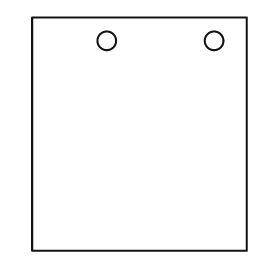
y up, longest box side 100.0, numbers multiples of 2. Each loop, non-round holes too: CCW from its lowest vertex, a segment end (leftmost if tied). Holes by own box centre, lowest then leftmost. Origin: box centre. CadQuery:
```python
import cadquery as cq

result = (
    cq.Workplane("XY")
    .moveTo(-46.0, -50.0)
    .lineTo(46.0, -50.0)
    .lineTo(46.0, 50.0)
    .lineTo(-46.0, 50.0)
    .close()
    .moveTo(-14.0, 40.0)
    .circle(4.0)
    .moveTo(32.0, 40.0)
    .circle(4.0)
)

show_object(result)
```